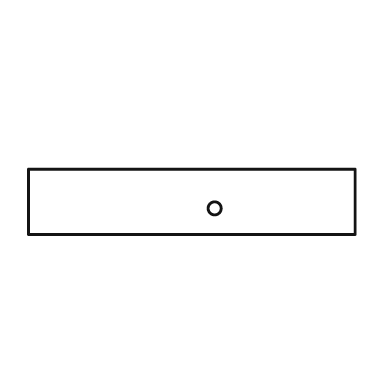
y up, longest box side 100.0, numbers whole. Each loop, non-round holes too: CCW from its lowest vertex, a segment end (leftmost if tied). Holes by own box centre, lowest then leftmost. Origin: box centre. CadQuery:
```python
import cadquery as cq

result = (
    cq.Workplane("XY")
    .moveTo(-50.0, -10.0)
    .lineTo(50.0, -10.0)
    .lineTo(50.0, 10.0)
    .lineTo(-50.0, 10.0)
    .close()
    .moveTo(7.0, -2.0)
    .circle(2.0)
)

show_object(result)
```